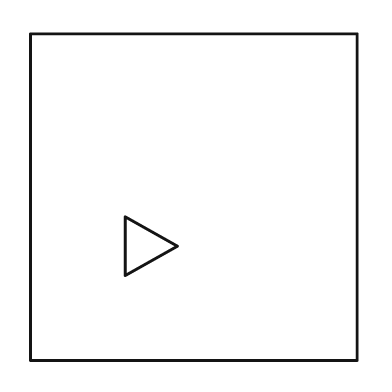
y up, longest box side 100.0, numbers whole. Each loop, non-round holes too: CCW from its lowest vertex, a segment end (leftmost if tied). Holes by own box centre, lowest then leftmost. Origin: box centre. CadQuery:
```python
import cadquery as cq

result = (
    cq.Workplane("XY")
    .moveTo(-50.0, -50.0)
    .lineTo(50.0, -50.0)
    .lineTo(50.0, 50.0)
    .lineTo(-50.0, 50.0)
    .close()
    .moveTo(-21.0, -24.0)
    .lineTo(-5.0, -15.0)
    .lineTo(-21.0, -6.0)
    .close()
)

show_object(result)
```